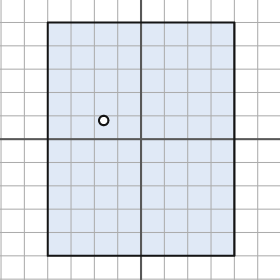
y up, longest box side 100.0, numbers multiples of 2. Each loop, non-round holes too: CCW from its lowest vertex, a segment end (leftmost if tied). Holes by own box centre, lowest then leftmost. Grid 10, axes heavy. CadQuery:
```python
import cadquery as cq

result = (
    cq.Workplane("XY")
    .moveTo(-40.0, -50.0)
    .lineTo(40.0, -50.0)
    .lineTo(40.0, 50.0)
    .lineTo(-40.0, 50.0)
    .close()
    .moveTo(-16.0, 8.0)
    .circle(2.0)
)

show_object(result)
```